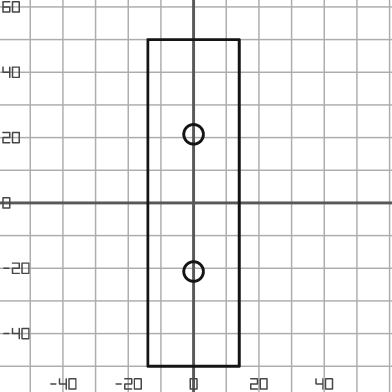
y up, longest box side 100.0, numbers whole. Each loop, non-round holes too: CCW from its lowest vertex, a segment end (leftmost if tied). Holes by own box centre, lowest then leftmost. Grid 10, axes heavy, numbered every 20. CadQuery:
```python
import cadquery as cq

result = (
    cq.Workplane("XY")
    .moveTo(-14.0, -50.0)
    .lineTo(14.0, -50.0)
    .lineTo(14.0, 50.0)
    .lineTo(-14.0, 50.0)
    .close()
    .moveTo(0.0, -21.0)
    .circle(3.0)
    .moveTo(0.0, 21.0)
    .circle(3.0)
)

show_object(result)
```